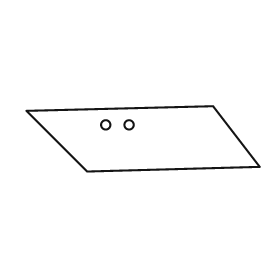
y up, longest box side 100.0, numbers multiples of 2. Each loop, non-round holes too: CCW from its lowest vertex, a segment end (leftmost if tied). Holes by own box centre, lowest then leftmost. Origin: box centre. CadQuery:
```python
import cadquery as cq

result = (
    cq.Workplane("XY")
    .moveTo(-24.0, -14.0)
    .lineTo(50.0, -12.0)
    .lineTo(30.0, 14.0)
    .lineTo(-50.0, 12.0)
    .close()
    .moveTo(-16.0, 6.0)
    .circle(2.0)
    .moveTo(-6.0, 6.0)
    .circle(2.0)
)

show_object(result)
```